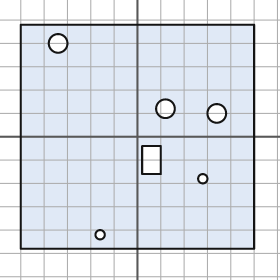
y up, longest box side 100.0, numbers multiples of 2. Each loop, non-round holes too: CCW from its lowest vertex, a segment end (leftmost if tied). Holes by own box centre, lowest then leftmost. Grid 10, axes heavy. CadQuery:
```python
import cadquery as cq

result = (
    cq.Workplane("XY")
    .moveTo(-50.0, -48.0)
    .lineTo(50.0, -48.0)
    .lineTo(50.0, 48.0)
    .lineTo(-50.0, 48.0)
    .close()
    .moveTo(-16.0, -42.0)
    .circle(2.0)
    .moveTo(28.0, -18.0)
    .circle(2.0)
    .moveTo(2.0, -16.0)
    .lineTo(10.0, -16.0)
    .lineTo(10.0, -4.0)
    .lineTo(2.0, -4.0)
    .close()
    .moveTo(34.0, 10.0)
    .circle(4.0)
    .moveTo(12.0, 12.0)
    .circle(4.0)
    .moveTo(-34.0, 40.0)
    .circle(4.0)
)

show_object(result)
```